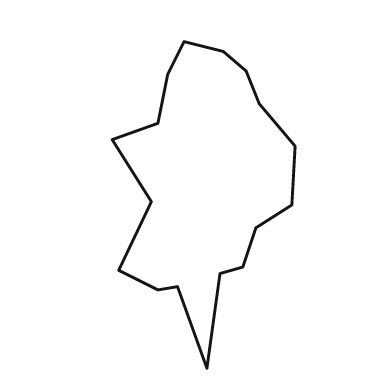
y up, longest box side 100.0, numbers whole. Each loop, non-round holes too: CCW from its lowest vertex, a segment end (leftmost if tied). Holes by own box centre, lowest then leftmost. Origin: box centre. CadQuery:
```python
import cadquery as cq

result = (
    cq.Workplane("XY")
    .moveTo(1.0, -50.0)
    .lineTo(5.0, -21.0)
    .lineTo(12.0, -19.0)
    .lineTo(16.0, -7.0)
    .lineTo(27.0, 0.0)
    .lineTo(28.0, 18.0)
    .lineTo(17.0, 31.0)
    .lineTo(13.0, 41.0)
    .lineTo(6.0, 47.0)
    .lineTo(-6.0, 50.0)
    .lineTo(-11.0, 40.0)
    .lineTo(-14.0, 25.0)
    .lineTo(-28.0, 20.0)
    .lineTo(-16.0, 1.0)
    .lineTo(-26.0, -20.0)
    .lineTo(-14.0, -26.0)
    .lineTo(-8.0, -25.0)
    .close()
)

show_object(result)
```